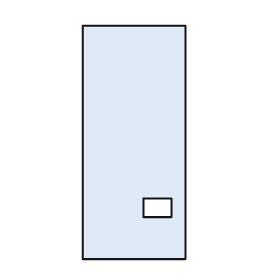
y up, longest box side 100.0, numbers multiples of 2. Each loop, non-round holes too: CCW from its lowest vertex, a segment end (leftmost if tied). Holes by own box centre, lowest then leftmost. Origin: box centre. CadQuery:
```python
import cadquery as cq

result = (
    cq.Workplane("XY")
    .moveTo(-22.0, -50.0)
    .lineTo(22.0, -50.0)
    .lineTo(22.0, 50.0)
    .lineTo(-22.0, 50.0)
    .close()
    .moveTo(4.0, -32.0)
    .lineTo(16.0, -32.0)
    .lineTo(16.0, -24.0)
    .lineTo(4.0, -24.0)
    .close()
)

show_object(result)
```